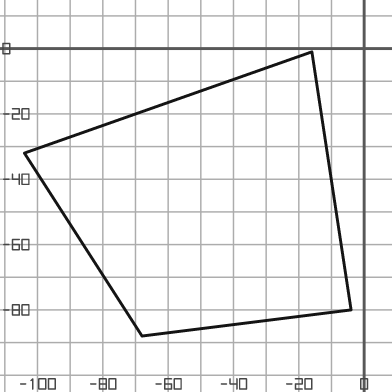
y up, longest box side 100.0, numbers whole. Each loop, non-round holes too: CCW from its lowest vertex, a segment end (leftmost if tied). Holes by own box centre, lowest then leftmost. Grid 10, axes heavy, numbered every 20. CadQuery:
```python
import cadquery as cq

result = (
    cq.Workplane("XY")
    .moveTo(-68.0, -88.0)
    .lineTo(-4.0, -80.0)
    .lineTo(-16.0, -1.0)
    .lineTo(-104.0, -32.0)
    .close()
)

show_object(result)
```